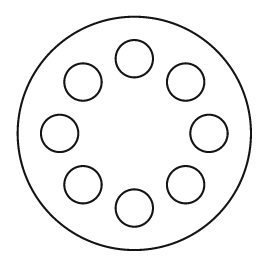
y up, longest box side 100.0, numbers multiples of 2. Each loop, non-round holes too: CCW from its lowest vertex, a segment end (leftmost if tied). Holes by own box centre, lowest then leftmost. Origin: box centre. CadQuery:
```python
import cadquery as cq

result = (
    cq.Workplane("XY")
    .moveTo(0.0, 0.0)
    .circle(50.0)
    .moveTo(0.0, -32.0)
    .circle(8.0)
    .moveTo(-22.0, -22.0)
    .circle(8.0)
    .moveTo(22.0, -22.0)
    .circle(8.0)
    .moveTo(-32.0, 0.0)
    .circle(8.0)
    .moveTo(32.0, 0.0)
    .circle(8.0)
    .moveTo(-22.0, 22.0)
    .circle(8.0)
    .moveTo(22.0, 22.0)
    .circle(8.0)
    .moveTo(0.0, 32.0)
    .circle(8.0)
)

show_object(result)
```